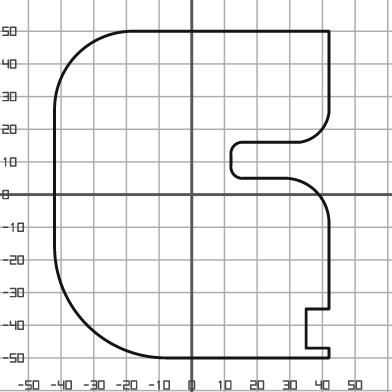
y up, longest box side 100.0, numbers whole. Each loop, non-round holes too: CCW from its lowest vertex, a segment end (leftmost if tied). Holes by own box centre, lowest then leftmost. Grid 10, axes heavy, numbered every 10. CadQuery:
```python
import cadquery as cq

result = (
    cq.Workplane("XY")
    .moveTo(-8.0, -50.0)
    .lineTo(42.0, -50.0)
    .lineTo(42.0, -47.0)
    .lineTo(35.0, -47.0)
    .lineTo(35.0, -35.0)
    .lineTo(42.0, -35.0)
    .lineTo(42.0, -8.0)
    .threePointArc((38.0, 1.0), (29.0, 5.0))
    .lineTo(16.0, 5.0)
    .threePointArc((13.0, 6.0), (12.0, 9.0))
    .lineTo(12.0, 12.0)
    .threePointArc((13.0, 15.0), (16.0, 16.0))
    .lineTo(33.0, 16.0)
    .threePointArc((39.0, 19.0), (42.0, 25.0))
    .lineTo(42.0, 50.0)
    .lineTo(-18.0, 50.0)
    .threePointArc((-35.0, 43.0), (-42.0, 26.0))
    .lineTo(-42.0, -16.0)
    .threePointArc((-32.0, -40.0), (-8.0, -50.0))
    .close()
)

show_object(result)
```